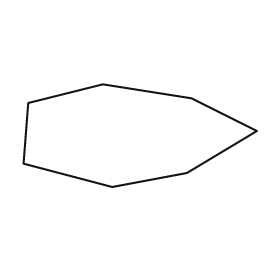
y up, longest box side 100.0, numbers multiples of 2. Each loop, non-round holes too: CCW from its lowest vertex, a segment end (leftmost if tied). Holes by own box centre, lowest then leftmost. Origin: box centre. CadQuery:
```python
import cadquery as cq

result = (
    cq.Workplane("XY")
    .moveTo(-12.0, -22.0)
    .lineTo(20.0, -16.0)
    .lineTo(50.0, 2.0)
    .lineTo(22.0, 16.0)
    .lineTo(-16.0, 22.0)
    .lineTo(-48.0, 14.0)
    .lineTo(-50.0, -12.0)
    .close()
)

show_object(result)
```